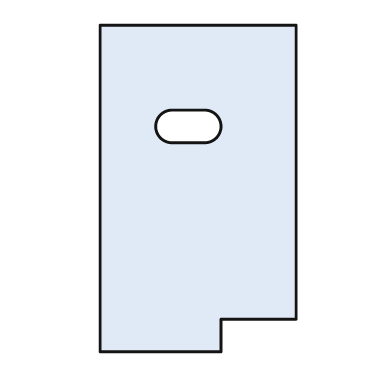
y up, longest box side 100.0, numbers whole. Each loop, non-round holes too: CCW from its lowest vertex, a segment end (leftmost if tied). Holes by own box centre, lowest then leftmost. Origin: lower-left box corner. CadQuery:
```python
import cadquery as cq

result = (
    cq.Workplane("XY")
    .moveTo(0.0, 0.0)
    .lineTo(37.0, 0.0)
    .lineTo(37.0, 10.0)
    .lineTo(60.0, 10.0)
    .lineTo(60.0, 100.0)
    .lineTo(0.0, 100.0)
    .close()
    .moveTo(22.0, 64.0)
    .lineTo(32.0, 64.0)
    .threePointArc((37.0, 69.0), (32.0, 74.0))
    .lineTo(22.0, 74.0)
    .threePointArc((17.0, 69.0), (22.0, 64.0))
    .close()
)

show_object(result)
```